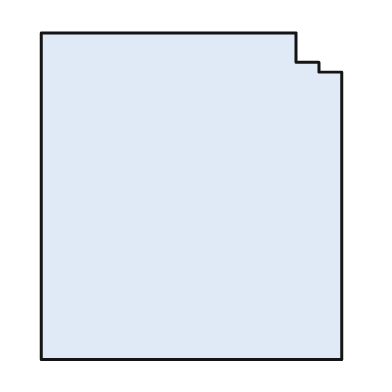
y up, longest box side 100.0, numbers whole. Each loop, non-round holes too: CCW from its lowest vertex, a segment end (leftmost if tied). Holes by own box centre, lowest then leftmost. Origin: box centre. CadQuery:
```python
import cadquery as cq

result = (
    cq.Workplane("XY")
    .moveTo(-46.0, -50.0)
    .lineTo(46.0, -50.0)
    .lineTo(46.0, 38.0)
    .lineTo(39.0, 38.0)
    .lineTo(39.0, 41.0)
    .lineTo(32.0, 41.0)
    .lineTo(32.0, 50.0)
    .lineTo(-46.0, 50.0)
    .close()
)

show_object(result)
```